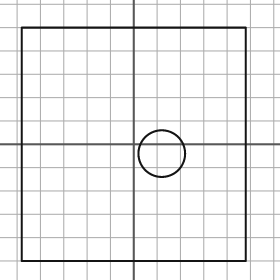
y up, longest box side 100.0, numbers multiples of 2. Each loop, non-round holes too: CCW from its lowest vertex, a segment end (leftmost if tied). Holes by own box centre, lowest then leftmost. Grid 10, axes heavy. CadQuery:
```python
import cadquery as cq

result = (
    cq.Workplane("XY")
    .moveTo(-48.0, -50.0)
    .lineTo(48.0, -50.0)
    .lineTo(48.0, 50.0)
    .lineTo(-48.0, 50.0)
    .close()
    .moveTo(12.0, -4.0)
    .circle(10.0)
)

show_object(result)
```